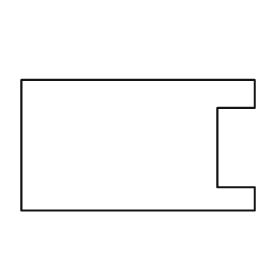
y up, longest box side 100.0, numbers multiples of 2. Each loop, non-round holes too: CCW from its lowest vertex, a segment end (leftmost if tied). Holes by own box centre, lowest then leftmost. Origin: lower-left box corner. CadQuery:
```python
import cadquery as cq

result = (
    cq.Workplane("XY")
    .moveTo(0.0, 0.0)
    .lineTo(100.0, 0.0)
    .lineTo(100.0, 10.0)
    .lineTo(84.0, 10.0)
    .lineTo(84.0, 44.0)
    .lineTo(100.0, 44.0)
    .lineTo(100.0, 56.0)
    .lineTo(0.0, 56.0)
    .close()
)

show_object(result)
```